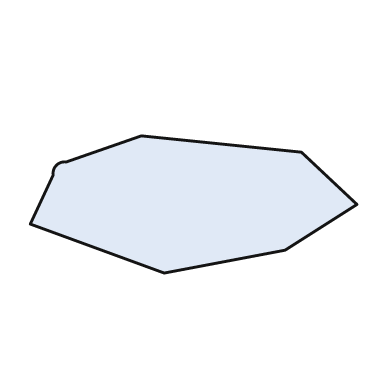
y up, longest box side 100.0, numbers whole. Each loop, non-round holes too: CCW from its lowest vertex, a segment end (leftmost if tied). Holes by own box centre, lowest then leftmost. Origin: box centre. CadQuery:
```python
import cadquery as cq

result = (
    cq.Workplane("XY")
    .moveTo(-9.0, -21.0)
    .lineTo(28.0, -14.0)
    .lineTo(50.0, 0.0)
    .lineTo(33.0, 16.0)
    .lineTo(-16.0, 21.0)
    .lineTo(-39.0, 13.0)
    .threePointArc((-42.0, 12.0), (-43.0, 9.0))
    .lineTo(-50.0, -6.0)
    .close()
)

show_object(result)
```